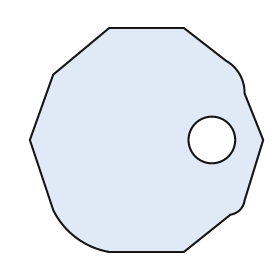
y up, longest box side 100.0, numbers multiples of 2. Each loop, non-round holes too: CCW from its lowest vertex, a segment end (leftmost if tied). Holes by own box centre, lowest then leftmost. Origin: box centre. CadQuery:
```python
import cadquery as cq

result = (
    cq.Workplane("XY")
    .moveTo(-16.0, -48.0)
    .lineTo(16.0, -48.0)
    .lineTo(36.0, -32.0)
    .threePointArc((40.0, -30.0), (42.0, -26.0))
    .lineTo(50.0, 0.0)
    .lineTo(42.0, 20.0)
    .threePointArc((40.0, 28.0), (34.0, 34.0))
    .lineTo(16.0, 48.0)
    .lineTo(-16.0, 48.0)
    .lineTo(-40.0, 28.0)
    .lineTo(-50.0, 0.0)
    .lineTo(-40.0, -30.0)
    .threePointArc((-30.0, -42.0), (-16.0, -48.0))
    .close()
    .moveTo(28.0, 0.0)
    .circle(10.0)
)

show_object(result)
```